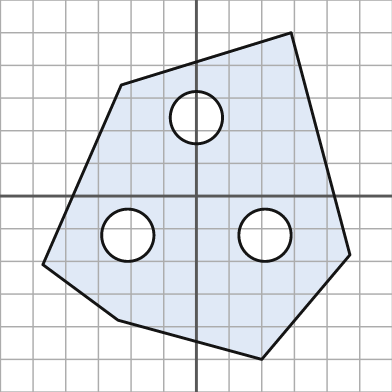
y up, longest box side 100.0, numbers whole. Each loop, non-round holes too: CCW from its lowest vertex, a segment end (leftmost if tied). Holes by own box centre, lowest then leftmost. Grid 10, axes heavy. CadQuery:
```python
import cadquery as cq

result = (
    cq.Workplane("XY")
    .moveTo(20.0, -50.0)
    .lineTo(47.0, -18.0)
    .lineTo(29.0, 50.0)
    .lineTo(-23.0, 34.0)
    .lineTo(-47.0, -21.0)
    .lineTo(-24.0, -38.0)
    .close()
    .moveTo(-21.0, -12.0)
    .circle(8.0)
    .moveTo(21.0, -12.0)
    .circle(8.0)
    .moveTo(0.0, 24.0)
    .circle(8.0)
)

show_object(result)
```